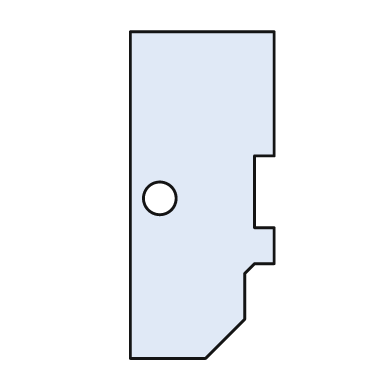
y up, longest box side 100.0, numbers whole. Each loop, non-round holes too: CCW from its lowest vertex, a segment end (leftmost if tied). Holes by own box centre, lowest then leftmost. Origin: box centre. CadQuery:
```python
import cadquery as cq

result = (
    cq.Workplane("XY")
    .moveTo(-22.0, -50.0)
    .lineTo(1.0, -50.0)
    .lineTo(13.0, -38.0)
    .lineTo(13.0, -24.0)
    .lineTo(16.0, -21.0)
    .lineTo(22.0, -21.0)
    .lineTo(22.0, -10.0)
    .lineTo(16.0, -10.0)
    .lineTo(16.0, 12.0)
    .lineTo(22.0, 12.0)
    .lineTo(22.0, 50.0)
    .lineTo(-22.0, 50.0)
    .close()
    .moveTo(-13.0, -1.0)
    .circle(5.0)
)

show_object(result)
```